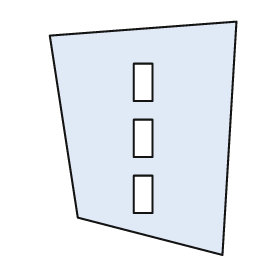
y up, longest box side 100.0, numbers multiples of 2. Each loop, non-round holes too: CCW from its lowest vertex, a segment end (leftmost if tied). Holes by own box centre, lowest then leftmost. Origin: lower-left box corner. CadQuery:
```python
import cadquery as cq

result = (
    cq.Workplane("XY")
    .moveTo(74.0, 0.0)
    .lineTo(80.0, 100.0)
    .lineTo(0.0, 94.0)
    .lineTo(12.0, 16.0)
    .close()
    .moveTo(36.0, 18.0)
    .lineTo(44.0, 18.0)
    .lineTo(44.0, 34.0)
    .lineTo(36.0, 34.0)
    .close()
    .moveTo(36.0, 42.0)
    .lineTo(44.0, 42.0)
    .lineTo(44.0, 58.0)
    .lineTo(36.0, 58.0)
    .close()
    .moveTo(36.0, 66.0)
    .lineTo(44.0, 66.0)
    .lineTo(44.0, 82.0)
    .lineTo(36.0, 82.0)
    .close()
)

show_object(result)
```